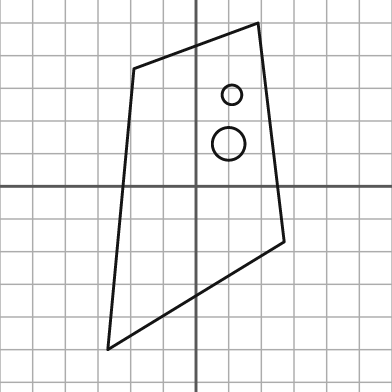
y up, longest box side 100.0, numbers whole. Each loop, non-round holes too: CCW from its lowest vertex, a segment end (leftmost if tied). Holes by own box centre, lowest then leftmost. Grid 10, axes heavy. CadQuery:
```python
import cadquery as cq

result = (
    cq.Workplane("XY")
    .moveTo(-27.0, -50.0)
    .lineTo(27.0, -17.0)
    .lineTo(19.0, 50.0)
    .lineTo(-19.0, 36.0)
    .close()
    .moveTo(10.0, 13.0)
    .circle(5.0)
    .moveTo(11.0, 28.0)
    .circle(3.0)
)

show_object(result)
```